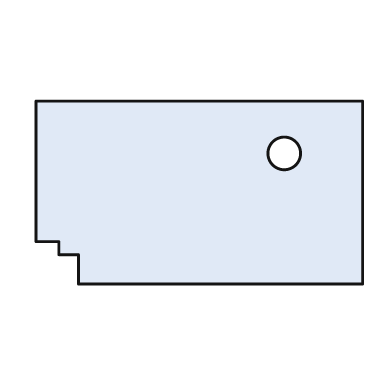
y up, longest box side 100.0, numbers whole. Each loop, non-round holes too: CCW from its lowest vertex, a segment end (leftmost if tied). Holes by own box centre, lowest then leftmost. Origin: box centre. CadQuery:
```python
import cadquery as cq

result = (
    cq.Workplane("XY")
    .moveTo(-37.0, -28.0)
    .lineTo(50.0, -28.0)
    .lineTo(50.0, 28.0)
    .lineTo(-50.0, 28.0)
    .lineTo(-50.0, -15.0)
    .lineTo(-43.0, -15.0)
    .lineTo(-43.0, -19.0)
    .lineTo(-37.0, -19.0)
    .close()
    .moveTo(26.0, 12.0)
    .circle(5.0)
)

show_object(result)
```